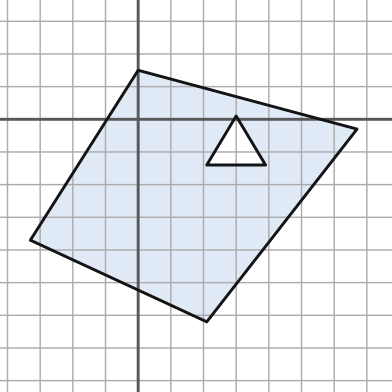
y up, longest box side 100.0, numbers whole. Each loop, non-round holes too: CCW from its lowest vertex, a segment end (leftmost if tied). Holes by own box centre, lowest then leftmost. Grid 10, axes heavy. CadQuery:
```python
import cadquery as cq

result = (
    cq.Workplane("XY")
    .moveTo(21.0, -62.0)
    .lineTo(67.0, -3.0)
    .lineTo(0.0, 15.0)
    .lineTo(-33.0, -37.0)
    .close()
    .moveTo(21.0, -14.0)
    .lineTo(39.0, -14.0)
    .lineTo(30.0, 1.0)
    .close()
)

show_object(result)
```